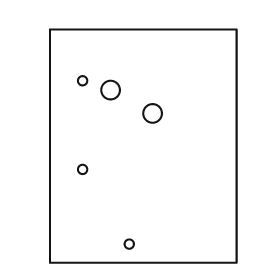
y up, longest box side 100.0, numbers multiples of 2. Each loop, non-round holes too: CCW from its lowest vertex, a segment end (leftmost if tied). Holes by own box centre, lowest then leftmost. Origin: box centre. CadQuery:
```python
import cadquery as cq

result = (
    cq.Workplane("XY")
    .moveTo(-40.0, -50.0)
    .lineTo(40.0, -50.0)
    .lineTo(40.0, 50.0)
    .lineTo(-40.0, 50.0)
    .close()
    .moveTo(-6.0, -42.0)
    .circle(2.0)
    .moveTo(-26.0, -10.0)
    .circle(2.0)
    .moveTo(4.0, 14.0)
    .circle(4.0)
    .moveTo(-14.0, 24.0)
    .circle(4.0)
    .moveTo(-26.0, 28.0)
    .circle(2.0)
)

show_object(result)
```